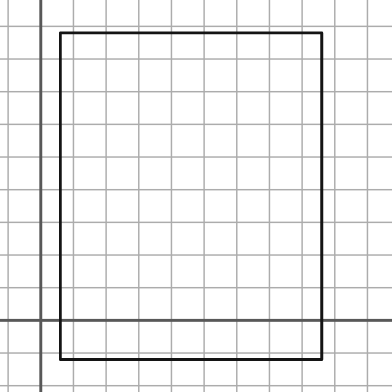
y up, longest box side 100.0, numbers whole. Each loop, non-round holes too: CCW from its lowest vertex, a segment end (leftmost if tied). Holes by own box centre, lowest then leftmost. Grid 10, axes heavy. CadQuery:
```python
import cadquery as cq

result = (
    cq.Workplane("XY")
    .moveTo(6.0, -12.0)
    .lineTo(86.0, -12.0)
    .lineTo(86.0, 88.0)
    .lineTo(6.0, 88.0)
    .close()
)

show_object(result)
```